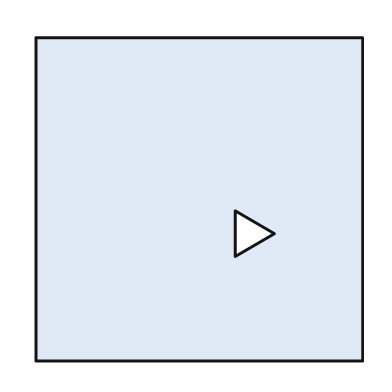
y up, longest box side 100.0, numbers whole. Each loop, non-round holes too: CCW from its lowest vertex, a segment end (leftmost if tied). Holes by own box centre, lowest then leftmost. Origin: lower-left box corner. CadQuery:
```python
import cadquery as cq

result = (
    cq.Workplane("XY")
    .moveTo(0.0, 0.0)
    .lineTo(100.0, 0.0)
    .lineTo(100.0, 99.0)
    .lineTo(0.0, 99.0)
    .close()
    .moveTo(61.0, 32.0)
    .lineTo(73.0, 39.0)
    .lineTo(61.0, 46.0)
    .close()
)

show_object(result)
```